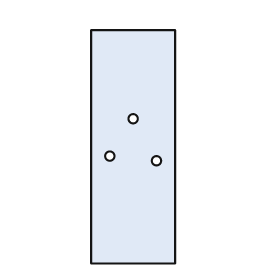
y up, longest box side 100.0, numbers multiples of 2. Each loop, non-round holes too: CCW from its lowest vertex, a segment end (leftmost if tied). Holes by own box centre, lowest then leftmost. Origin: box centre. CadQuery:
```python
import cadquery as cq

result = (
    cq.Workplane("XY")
    .moveTo(-18.0, -50.0)
    .lineTo(18.0, -50.0)
    .lineTo(18.0, 50.0)
    .lineTo(-18.0, 50.0)
    .close()
    .moveTo(10.0, -6.0)
    .circle(2.0)
    .moveTo(-10.0, -4.0)
    .circle(2.0)
    .moveTo(0.0, 12.0)
    .circle(2.0)
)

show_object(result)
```